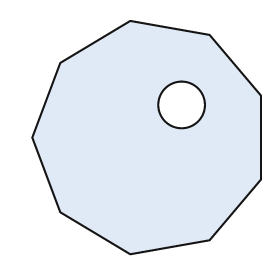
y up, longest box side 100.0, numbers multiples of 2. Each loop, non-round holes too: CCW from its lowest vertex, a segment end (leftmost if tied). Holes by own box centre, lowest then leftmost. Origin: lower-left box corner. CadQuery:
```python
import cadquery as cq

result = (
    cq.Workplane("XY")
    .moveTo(42.0, 0.0)
    .lineTo(76.0, 6.0)
    .lineTo(98.0, 32.0)
    .lineTo(98.0, 68.0)
    .lineTo(76.0, 94.0)
    .lineTo(42.0, 100.0)
    .lineTo(12.0, 82.0)
    .lineTo(0.0, 50.0)
    .lineTo(12.0, 18.0)
    .close()
    .moveTo(64.0, 64.0)
    .circle(10.0)
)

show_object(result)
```